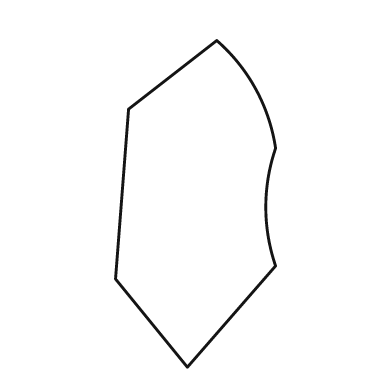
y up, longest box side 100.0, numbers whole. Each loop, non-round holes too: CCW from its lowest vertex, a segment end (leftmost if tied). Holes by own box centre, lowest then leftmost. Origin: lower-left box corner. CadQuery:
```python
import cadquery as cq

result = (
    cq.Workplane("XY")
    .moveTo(22.0, 0.0)
    .lineTo(49.0, 31.0)
    .threePointArc((46.0, 49.0), (49.0, 67.0))
    .threePointArc((43.0, 85.0), (31.0, 100.0))
    .lineTo(4.0, 79.0)
    .lineTo(0.0, 27.0)
    .close()
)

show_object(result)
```